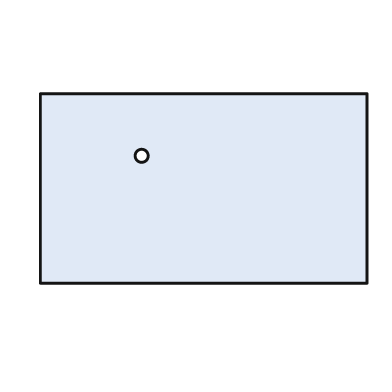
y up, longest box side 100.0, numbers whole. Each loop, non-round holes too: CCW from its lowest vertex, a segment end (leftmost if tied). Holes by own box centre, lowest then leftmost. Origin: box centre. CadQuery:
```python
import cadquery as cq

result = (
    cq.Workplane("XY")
    .moveTo(-50.0, -29.0)
    .lineTo(50.0, -29.0)
    .lineTo(50.0, 29.0)
    .lineTo(-50.0, 29.0)
    .close()
    .moveTo(-19.0, 10.0)
    .circle(2.0)
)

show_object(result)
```